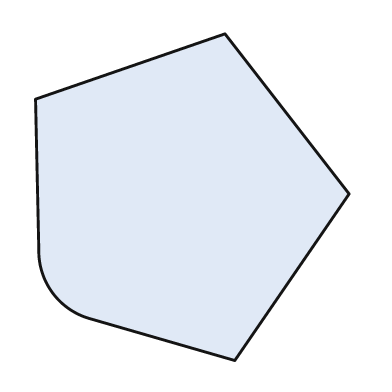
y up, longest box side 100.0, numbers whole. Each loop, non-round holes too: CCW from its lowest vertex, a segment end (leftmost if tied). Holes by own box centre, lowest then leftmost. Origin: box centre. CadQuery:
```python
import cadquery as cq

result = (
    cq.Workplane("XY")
    .moveTo(13.0, -50.0)
    .lineTo(48.0, 1.0)
    .lineTo(10.0, 50.0)
    .lineTo(-48.0, 30.0)
    .lineTo(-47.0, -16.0)
    .threePointArc((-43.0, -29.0), (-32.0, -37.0))
    .close()
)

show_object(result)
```